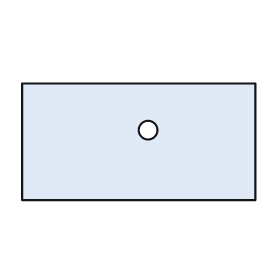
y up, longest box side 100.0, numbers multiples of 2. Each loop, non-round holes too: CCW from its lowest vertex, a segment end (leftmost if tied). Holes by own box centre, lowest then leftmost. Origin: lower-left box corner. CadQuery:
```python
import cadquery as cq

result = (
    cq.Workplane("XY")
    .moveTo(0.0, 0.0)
    .lineTo(100.0, 0.0)
    .lineTo(100.0, 50.0)
    .lineTo(0.0, 50.0)
    .close()
    .moveTo(54.0, 30.0)
    .circle(4.0)
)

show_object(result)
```